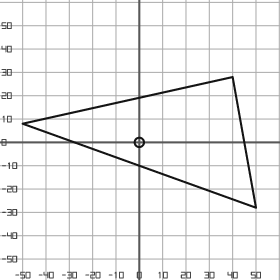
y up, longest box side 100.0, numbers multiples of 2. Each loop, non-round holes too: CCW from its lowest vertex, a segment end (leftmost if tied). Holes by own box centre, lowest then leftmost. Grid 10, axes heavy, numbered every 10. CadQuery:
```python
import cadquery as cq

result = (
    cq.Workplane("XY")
    .moveTo(50.0, -28.0)
    .lineTo(40.0, 28.0)
    .lineTo(-50.0, 8.0)
    .close()
    .moveTo(0.0, 0.0)
    .circle(2.0)
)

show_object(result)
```